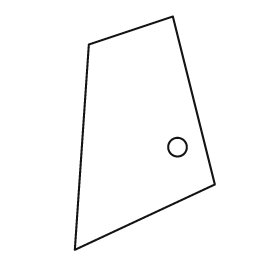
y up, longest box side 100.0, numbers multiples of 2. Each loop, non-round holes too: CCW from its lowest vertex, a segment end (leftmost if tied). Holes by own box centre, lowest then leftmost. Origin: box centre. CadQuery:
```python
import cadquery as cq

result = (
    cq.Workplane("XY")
    .moveTo(-30.0, -50.0)
    .lineTo(30.0, -22.0)
    .lineTo(12.0, 50.0)
    .lineTo(-24.0, 38.0)
    .close()
    .moveTo(14.0, -6.0)
    .circle(4.0)
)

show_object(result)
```